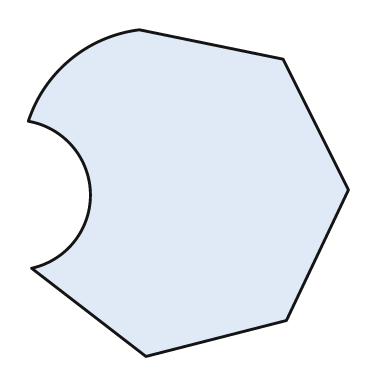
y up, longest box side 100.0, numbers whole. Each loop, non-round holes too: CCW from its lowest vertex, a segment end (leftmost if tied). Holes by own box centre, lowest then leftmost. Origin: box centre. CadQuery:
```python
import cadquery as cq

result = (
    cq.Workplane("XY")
    .moveTo(-13.0, -50.0)
    .lineTo(30.0, -39.0)
    .lineTo(49.0, 1.0)
    .lineTo(29.0, 41.0)
    .lineTo(-15.0, 50.0)
    .threePointArc((-36.0, 41.0), (-49.0, 22.0))
    .threePointArc((-30.0, 0.0), (-48.0, -23.0))
    .close()
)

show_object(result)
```